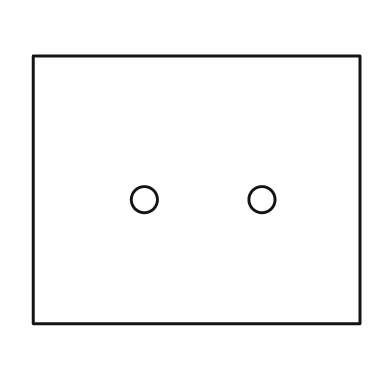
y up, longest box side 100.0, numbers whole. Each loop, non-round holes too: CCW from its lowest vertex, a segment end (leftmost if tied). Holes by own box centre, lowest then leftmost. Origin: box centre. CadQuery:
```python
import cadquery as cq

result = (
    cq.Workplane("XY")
    .moveTo(-50.0, -41.0)
    .lineTo(50.0, -41.0)
    .lineTo(50.0, 41.0)
    .lineTo(-50.0, 41.0)
    .close()
    .moveTo(-16.0, -3.0)
    .circle(4.0)
    .moveTo(20.0, -3.0)
    .circle(4.0)
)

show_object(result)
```